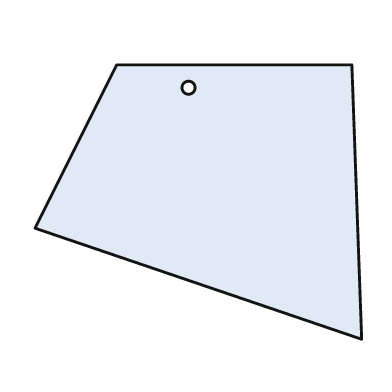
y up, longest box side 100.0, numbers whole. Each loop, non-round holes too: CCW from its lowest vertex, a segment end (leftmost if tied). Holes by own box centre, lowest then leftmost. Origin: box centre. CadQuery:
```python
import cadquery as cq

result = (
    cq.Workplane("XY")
    .moveTo(50.0, -42.0)
    .lineTo(47.0, 42.0)
    .lineTo(-25.0, 42.0)
    .lineTo(-50.0, -8.0)
    .close()
    .moveTo(-3.0, 35.0)
    .circle(2.0)
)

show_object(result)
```